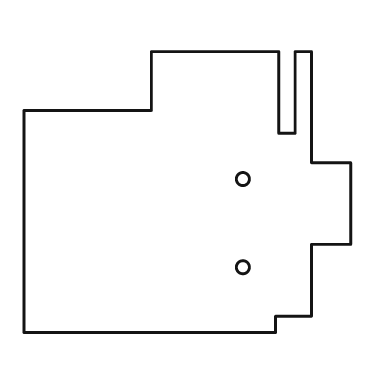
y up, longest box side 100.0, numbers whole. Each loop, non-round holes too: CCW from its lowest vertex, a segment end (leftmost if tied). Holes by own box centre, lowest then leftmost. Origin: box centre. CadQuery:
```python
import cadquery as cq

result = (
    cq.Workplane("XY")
    .moveTo(-50.0, -43.0)
    .lineTo(27.0, -43.0)
    .lineTo(27.0, -38.0)
    .lineTo(38.0, -38.0)
    .lineTo(38.0, -16.0)
    .lineTo(50.0, -16.0)
    .lineTo(50.0, 9.0)
    .lineTo(38.0, 9.0)
    .lineTo(38.0, 43.0)
    .lineTo(33.0, 43.0)
    .lineTo(33.0, 18.0)
    .lineTo(28.0, 18.0)
    .lineTo(28.0, 43.0)
    .lineTo(-11.0, 43.0)
    .lineTo(-11.0, 25.0)
    .lineTo(-50.0, 25.0)
    .close()
    .moveTo(17.0, -23.0)
    .circle(2.0)
    .moveTo(17.0, 4.0)
    .circle(2.0)
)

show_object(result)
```